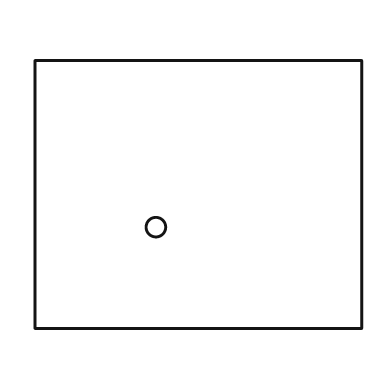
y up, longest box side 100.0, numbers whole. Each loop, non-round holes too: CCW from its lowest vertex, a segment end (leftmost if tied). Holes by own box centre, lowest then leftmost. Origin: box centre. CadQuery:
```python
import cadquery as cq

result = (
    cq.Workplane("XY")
    .moveTo(-50.0, -41.0)
    .lineTo(50.0, -41.0)
    .lineTo(50.0, 41.0)
    .lineTo(-50.0, 41.0)
    .close()
    .moveTo(-13.0, -10.0)
    .circle(3.0)
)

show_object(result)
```